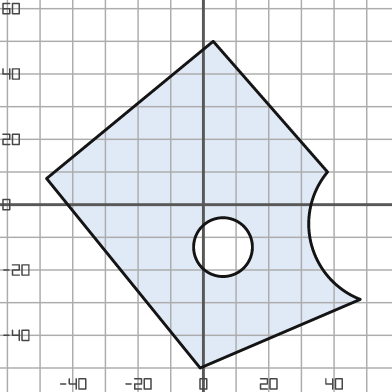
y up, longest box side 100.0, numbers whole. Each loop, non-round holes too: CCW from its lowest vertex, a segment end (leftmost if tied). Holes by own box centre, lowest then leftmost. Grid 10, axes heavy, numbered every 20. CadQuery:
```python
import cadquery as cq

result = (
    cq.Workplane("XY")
    .moveTo(-1.0, -50.0)
    .lineTo(48.0, -29.0)
    .threePointArc((33.0, -12.0), (38.0, 10.0))
    .lineTo(3.0, 50.0)
    .lineTo(-48.0, 8.0)
    .close()
    .moveTo(6.0, -13.0)
    .circle(9.0)
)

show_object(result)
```